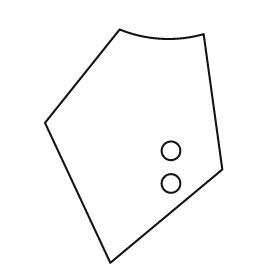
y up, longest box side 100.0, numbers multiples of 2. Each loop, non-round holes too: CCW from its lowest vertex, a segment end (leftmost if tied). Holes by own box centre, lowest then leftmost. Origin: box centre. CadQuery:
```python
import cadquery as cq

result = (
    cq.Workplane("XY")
    .moveTo(-10.0, -50.0)
    .lineTo(38.0, -10.0)
    .lineTo(30.0, 48.0)
    .threePointArc((12.0, 46.0), (-6.0, 50.0))
    .lineTo(-38.0, 10.0)
    .close()
    .moveTo(16.0, -16.0)
    .circle(4.0)
    .moveTo(16.0, -2.0)
    .circle(4.0)
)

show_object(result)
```